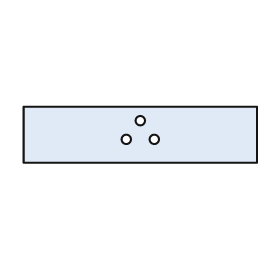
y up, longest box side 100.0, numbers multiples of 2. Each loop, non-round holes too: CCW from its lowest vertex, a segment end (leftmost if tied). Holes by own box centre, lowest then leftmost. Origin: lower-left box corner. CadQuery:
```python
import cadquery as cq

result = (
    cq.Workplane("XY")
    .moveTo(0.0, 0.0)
    .lineTo(100.0, 0.0)
    .lineTo(100.0, 24.0)
    .lineTo(0.0, 24.0)
    .close()
    .moveTo(44.0, 10.0)
    .circle(2.0)
    .moveTo(56.0, 10.0)
    .circle(2.0)
    .moveTo(50.0, 18.0)
    .circle(2.0)
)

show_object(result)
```